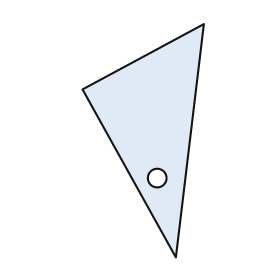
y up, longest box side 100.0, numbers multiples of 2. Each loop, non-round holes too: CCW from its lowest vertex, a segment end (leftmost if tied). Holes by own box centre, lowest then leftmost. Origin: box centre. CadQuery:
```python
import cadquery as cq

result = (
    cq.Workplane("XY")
    .moveTo(14.0, -50.0)
    .lineTo(26.0, 50.0)
    .lineTo(-26.0, 22.0)
    .close()
    .moveTo(6.0, -16.0)
    .circle(4.0)
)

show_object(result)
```